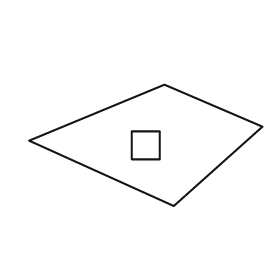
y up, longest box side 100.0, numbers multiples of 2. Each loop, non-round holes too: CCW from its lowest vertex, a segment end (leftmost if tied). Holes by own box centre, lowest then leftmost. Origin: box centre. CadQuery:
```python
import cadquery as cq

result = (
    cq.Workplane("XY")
    .moveTo(12.0, -26.0)
    .lineTo(50.0, 8.0)
    .lineTo(8.0, 26.0)
    .lineTo(-50.0, 2.0)
    .close()
    .moveTo(-6.0, -6.0)
    .lineTo(6.0, -6.0)
    .lineTo(6.0, 6.0)
    .lineTo(-6.0, 6.0)
    .close()
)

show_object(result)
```